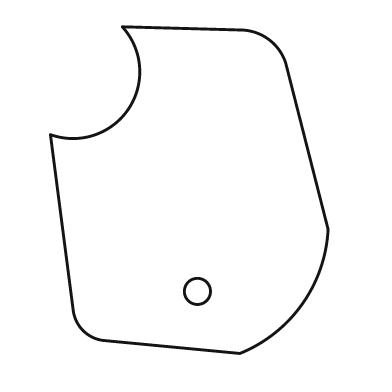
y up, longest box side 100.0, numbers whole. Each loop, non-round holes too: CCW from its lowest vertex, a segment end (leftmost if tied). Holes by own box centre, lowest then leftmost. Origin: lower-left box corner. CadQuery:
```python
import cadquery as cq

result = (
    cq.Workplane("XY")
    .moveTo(58.0, 0.0)
    .threePointArc((77.0, 15.0), (85.0, 38.0))
    .lineTo(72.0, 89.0)
    .threePointArc((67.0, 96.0), (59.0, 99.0))
    .lineTo(22.0, 100.0)
    .threePointArc((24.0, 75.0), (0.0, 67.0))
    .lineTo(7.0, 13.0)
    .threePointArc((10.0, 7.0), (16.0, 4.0))
    .close()
    .moveTo(45.0, 19.0)
    .circle(4.0)
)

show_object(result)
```